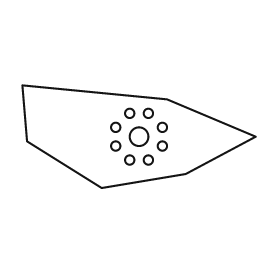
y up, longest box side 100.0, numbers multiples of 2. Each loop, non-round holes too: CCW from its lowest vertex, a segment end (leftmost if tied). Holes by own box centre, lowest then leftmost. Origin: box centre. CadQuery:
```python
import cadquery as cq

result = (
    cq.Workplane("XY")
    .moveTo(-16.0, -22.0)
    .lineTo(20.0, -16.0)
    .lineTo(50.0, 0.0)
    .lineTo(12.0, 16.0)
    .lineTo(-50.0, 22.0)
    .lineTo(-48.0, -2.0)
    .close()
    .moveTo(-4.0, -10.0)
    .circle(2.0)
    .moveTo(4.0, -10.0)
    .circle(2.0)
    .moveTo(-10.0, -4.0)
    .circle(2.0)
    .moveTo(10.0, -4.0)
    .circle(2.0)
    .moveTo(0.0, 0.0)
    .circle(4.0)
    .moveTo(-10.0, 4.0)
    .circle(2.0)
    .moveTo(10.0, 4.0)
    .circle(2.0)
    .moveTo(-4.0, 10.0)
    .circle(2.0)
    .moveTo(4.0, 10.0)
    .circle(2.0)
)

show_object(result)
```